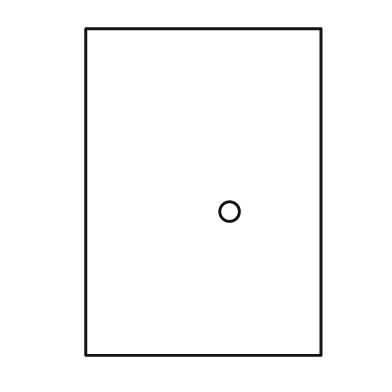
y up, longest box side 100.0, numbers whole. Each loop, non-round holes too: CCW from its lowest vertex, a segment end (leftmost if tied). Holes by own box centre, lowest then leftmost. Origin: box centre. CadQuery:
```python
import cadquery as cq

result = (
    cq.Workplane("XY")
    .moveTo(-36.0, -50.0)
    .lineTo(36.0, -50.0)
    .lineTo(36.0, 50.0)
    .lineTo(-36.0, 50.0)
    .close()
    .moveTo(8.0, -6.0)
    .circle(3.0)
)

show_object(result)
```